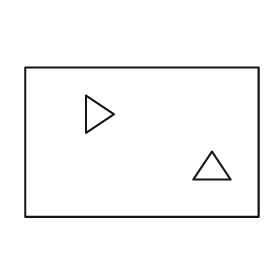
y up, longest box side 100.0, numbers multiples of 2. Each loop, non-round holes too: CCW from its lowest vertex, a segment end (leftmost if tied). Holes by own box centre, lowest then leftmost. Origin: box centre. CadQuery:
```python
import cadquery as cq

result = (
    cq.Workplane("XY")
    .moveTo(-50.0, -32.0)
    .lineTo(50.0, -32.0)
    .lineTo(50.0, 32.0)
    .lineTo(-50.0, 32.0)
    .close()
    .moveTo(22.0, -16.0)
    .lineTo(38.0, -16.0)
    .lineTo(30.0, -4.0)
    .close()
    .moveTo(-24.0, 4.0)
    .lineTo(-12.0, 12.0)
    .lineTo(-24.0, 20.0)
    .close()
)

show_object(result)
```